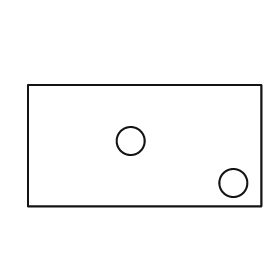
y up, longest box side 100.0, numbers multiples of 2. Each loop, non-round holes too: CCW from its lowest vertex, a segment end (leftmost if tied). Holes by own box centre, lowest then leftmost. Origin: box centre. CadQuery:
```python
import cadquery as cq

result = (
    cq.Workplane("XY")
    .moveTo(-50.0, -26.0)
    .lineTo(50.0, -26.0)
    .lineTo(50.0, 26.0)
    .lineTo(-50.0, 26.0)
    .close()
    .moveTo(38.0, -16.0)
    .circle(6.0)
    .moveTo(-6.0, 2.0)
    .circle(6.0)
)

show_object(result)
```